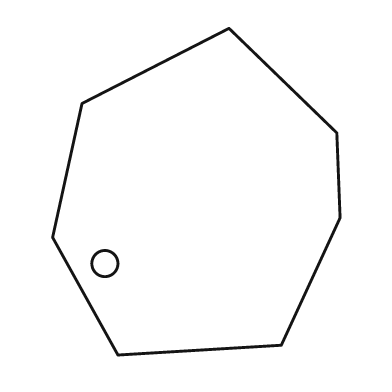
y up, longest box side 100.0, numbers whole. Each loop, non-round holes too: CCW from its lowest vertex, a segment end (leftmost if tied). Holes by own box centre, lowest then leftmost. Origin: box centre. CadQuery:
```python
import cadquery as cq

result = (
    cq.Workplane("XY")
    .moveTo(-24.0, -50.0)
    .lineTo(26.0, -47.0)
    .lineTo(44.0, -8.0)
    .lineTo(43.0, 18.0)
    .lineTo(10.0, 50.0)
    .lineTo(-35.0, 27.0)
    .lineTo(-44.0, -14.0)
    .close()
    .moveTo(-28.0, -22.0)
    .circle(4.0)
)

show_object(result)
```